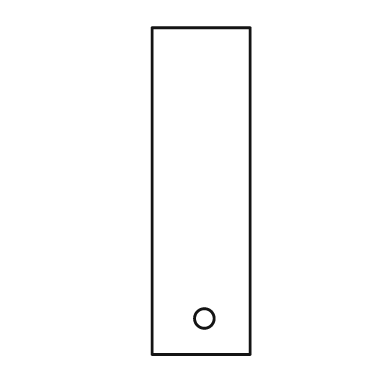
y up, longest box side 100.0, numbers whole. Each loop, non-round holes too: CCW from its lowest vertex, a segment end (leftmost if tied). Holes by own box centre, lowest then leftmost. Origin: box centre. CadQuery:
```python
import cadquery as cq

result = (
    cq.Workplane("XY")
    .moveTo(-15.0, -50.0)
    .lineTo(15.0, -50.0)
    .lineTo(15.0, 50.0)
    .lineTo(-15.0, 50.0)
    .close()
    .moveTo(1.0, -39.0)
    .circle(3.0)
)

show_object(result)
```